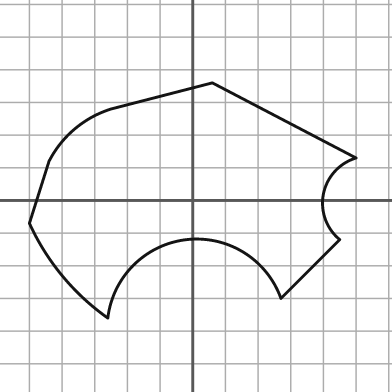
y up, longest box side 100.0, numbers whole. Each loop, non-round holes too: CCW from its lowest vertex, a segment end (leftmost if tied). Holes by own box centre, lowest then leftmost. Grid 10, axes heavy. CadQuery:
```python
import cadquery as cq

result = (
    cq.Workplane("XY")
    .moveTo(-26.0, -36.0)
    .threePointArc((-2.0, -12.0), (27.0, -30.0))
    .lineTo(45.0, -12.0)
    .threePointArc((40.0, 2.0), (50.0, 13.0))
    .lineTo(6.0, 36.0)
    .lineTo(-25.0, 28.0)
    .threePointArc((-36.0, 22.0), (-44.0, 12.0))
    .lineTo(-50.0, -7.0)
    .threePointArc((-40.0, -23.0), (-26.0, -36.0))
    .close()
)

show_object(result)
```